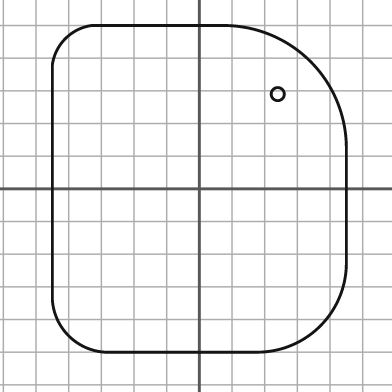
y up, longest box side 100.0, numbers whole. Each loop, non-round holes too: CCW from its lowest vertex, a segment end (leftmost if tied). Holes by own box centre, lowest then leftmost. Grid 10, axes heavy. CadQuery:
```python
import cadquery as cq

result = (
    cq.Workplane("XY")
    .moveTo(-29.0, -50.0)
    .lineTo(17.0, -50.0)
    .threePointArc((37.0, -42.0), (45.0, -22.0))
    .lineTo(45.0, 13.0)
    .threePointArc((34.0, 39.0), (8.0, 50.0))
    .lineTo(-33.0, 50.0)
    .threePointArc((-41.0, 46.0), (-45.0, 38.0))
    .lineTo(-45.0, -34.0)
    .threePointArc((-40.0, -45.0), (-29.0, -50.0))
    .close()
    .moveTo(24.0, 29.0)
    .circle(2.0)
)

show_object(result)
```